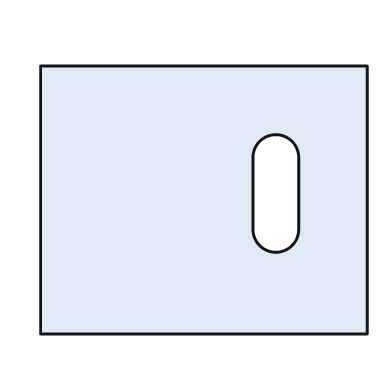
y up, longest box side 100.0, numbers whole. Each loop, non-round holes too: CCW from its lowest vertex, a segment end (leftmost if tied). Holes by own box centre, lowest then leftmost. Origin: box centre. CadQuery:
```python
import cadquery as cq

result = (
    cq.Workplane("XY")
    .moveTo(-50.0, -41.0)
    .lineTo(50.0, -41.0)
    .lineTo(50.0, 41.0)
    .lineTo(-50.0, 41.0)
    .close()
    .moveTo(15.0, -9.0)
    .threePointArc((22.0, -16.0), (29.0, -9.0))
    .lineTo(29.0, 13.0)
    .threePointArc((22.0, 20.0), (15.0, 13.0))
    .close()
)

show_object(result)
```